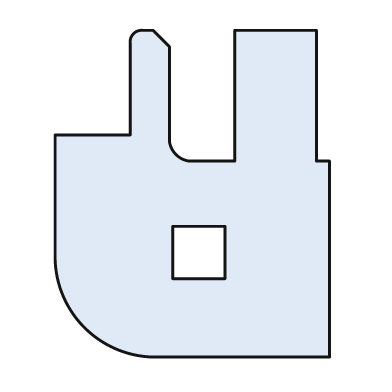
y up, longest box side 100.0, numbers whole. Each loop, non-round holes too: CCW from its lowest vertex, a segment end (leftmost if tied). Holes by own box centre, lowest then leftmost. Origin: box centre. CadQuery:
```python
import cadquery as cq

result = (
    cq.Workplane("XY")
    .moveTo(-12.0, -50.0)
    .lineTo(42.0, -50.0)
    .lineTo(42.0, 10.0)
    .lineTo(38.0, 10.0)
    .lineTo(38.0, 50.0)
    .lineTo(13.0, 50.0)
    .lineTo(13.0, 10.0)
    .lineTo(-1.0, 10.0)
    .threePointArc((-5.0, 12.0), (-7.0, 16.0))
    .lineTo(-7.0, 45.0)
    .lineTo(-12.0, 50.0)
    .lineTo(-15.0, 50.0)
    .threePointArc((-18.0, 49.0), (-19.0, 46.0))
    .lineTo(-19.0, 18.0)
    .lineTo(-42.0, 18.0)
    .lineTo(-42.0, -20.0)
    .threePointArc((-33.0, -41.0), (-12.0, -50.0))
    .close()
    .moveTo(-6.0, -26.0)
    .lineTo(10.0, -26.0)
    .lineTo(10.0, -10.0)
    .lineTo(-6.0, -10.0)
    .close()
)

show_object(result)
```